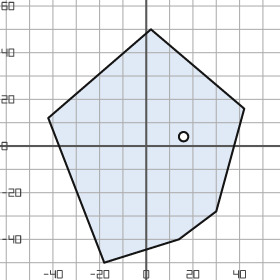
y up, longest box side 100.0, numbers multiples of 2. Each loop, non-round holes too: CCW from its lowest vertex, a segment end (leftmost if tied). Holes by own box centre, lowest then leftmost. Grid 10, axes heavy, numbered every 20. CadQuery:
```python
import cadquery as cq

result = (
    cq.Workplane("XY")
    .moveTo(-18.0, -50.0)
    .lineTo(14.0, -40.0)
    .lineTo(30.0, -28.0)
    .lineTo(42.0, 16.0)
    .lineTo(2.0, 50.0)
    .lineTo(-42.0, 12.0)
    .close()
    .moveTo(16.0, 4.0)
    .circle(2.0)
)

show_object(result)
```